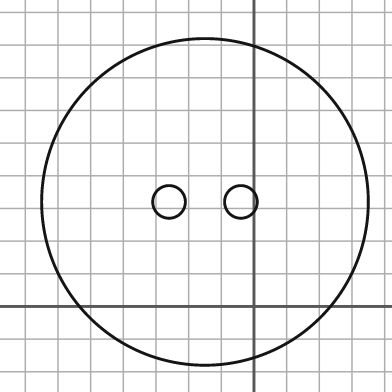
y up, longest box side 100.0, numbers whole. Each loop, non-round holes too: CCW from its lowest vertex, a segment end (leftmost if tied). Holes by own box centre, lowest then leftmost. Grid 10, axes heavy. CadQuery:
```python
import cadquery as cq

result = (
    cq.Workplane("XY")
    .moveTo(-15.0, 32.0)
    .circle(50.0)
    .moveTo(-26.0, 32.0)
    .circle(5.0)
    .moveTo(-4.0, 32.0)
    .circle(5.0)
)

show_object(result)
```